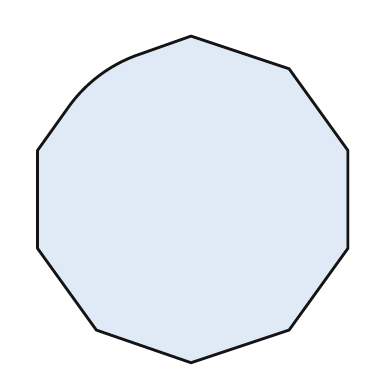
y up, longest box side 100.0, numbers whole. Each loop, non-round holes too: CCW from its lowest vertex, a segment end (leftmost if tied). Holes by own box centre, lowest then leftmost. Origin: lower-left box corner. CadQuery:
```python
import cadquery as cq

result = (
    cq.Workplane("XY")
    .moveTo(47.0, 0.0)
    .lineTo(77.0, 10.0)
    .lineTo(95.0, 35.0)
    .lineTo(95.0, 65.0)
    .lineTo(77.0, 90.0)
    .lineTo(47.0, 100.0)
    .lineTo(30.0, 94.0)
    .threePointArc((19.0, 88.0), (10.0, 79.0))
    .lineTo(0.0, 65.0)
    .lineTo(0.0, 35.0)
    .lineTo(18.0, 10.0)
    .close()
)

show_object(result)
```